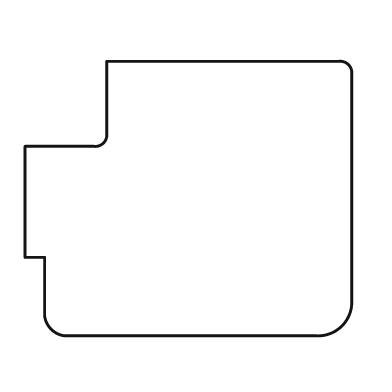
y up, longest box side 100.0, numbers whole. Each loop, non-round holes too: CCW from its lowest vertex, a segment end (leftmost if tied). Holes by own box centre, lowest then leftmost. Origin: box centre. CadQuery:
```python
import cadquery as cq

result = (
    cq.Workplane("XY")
    .moveTo(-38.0, -42.0)
    .lineTo(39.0, -42.0)
    .threePointArc((47.0, -39.0), (50.0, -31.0))
    .lineTo(50.0, 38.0)
    .threePointArc((49.0, 41.0), (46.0, 42.0))
    .lineTo(-25.0, 42.0)
    .lineTo(-25.0, 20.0)
    .threePointArc((-26.0, 17.0), (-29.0, 16.0))
    .lineTo(-50.0, 16.0)
    .lineTo(-50.0, -18.0)
    .lineTo(-44.0, -18.0)
    .lineTo(-44.0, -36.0)
    .threePointArc((-42.0, -40.0), (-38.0, -42.0))
    .close()
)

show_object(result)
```